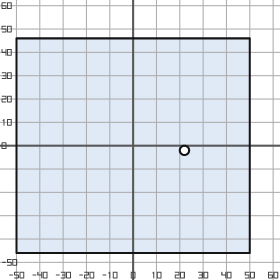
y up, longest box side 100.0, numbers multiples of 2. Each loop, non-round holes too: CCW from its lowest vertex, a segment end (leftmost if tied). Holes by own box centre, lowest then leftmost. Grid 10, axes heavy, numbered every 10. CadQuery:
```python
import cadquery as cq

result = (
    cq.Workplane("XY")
    .moveTo(-50.0, -46.0)
    .lineTo(50.0, -46.0)
    .lineTo(50.0, 46.0)
    .lineTo(-50.0, 46.0)
    .close()
    .moveTo(22.0, -2.0)
    .circle(2.0)
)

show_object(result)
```